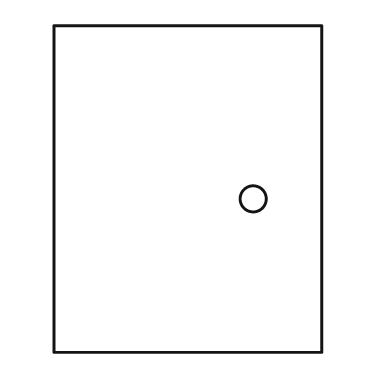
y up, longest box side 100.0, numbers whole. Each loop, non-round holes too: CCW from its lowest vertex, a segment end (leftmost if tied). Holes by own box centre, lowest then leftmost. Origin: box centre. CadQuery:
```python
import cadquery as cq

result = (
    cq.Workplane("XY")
    .moveTo(-41.0, -50.0)
    .lineTo(41.0, -50.0)
    .lineTo(41.0, 50.0)
    .lineTo(-41.0, 50.0)
    .close()
    .moveTo(20.0, -3.0)
    .circle(4.0)
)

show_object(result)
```